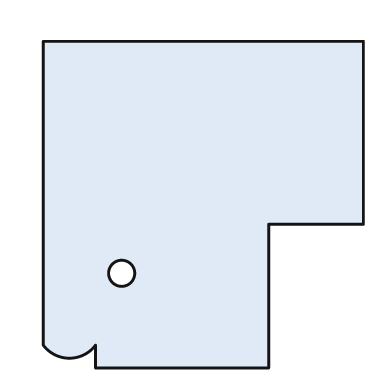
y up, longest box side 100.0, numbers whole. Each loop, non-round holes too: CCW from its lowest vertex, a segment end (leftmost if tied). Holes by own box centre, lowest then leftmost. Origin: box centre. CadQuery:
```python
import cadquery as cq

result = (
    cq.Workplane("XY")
    .moveTo(-33.0, -50.0)
    .lineTo(20.0, -50.0)
    .lineTo(20.0, -6.0)
    .lineTo(49.0, -6.0)
    .lineTo(49.0, 50.0)
    .lineTo(-49.0, 50.0)
    .lineTo(-49.0, -43.0)
    .threePointArc((-41.0, -47.0), (-33.0, -43.0))
    .close()
    .moveTo(-25.0, -21.0)
    .circle(4.0)
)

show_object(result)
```